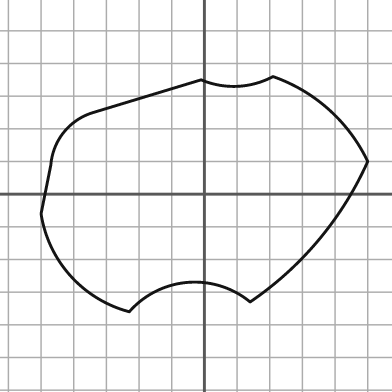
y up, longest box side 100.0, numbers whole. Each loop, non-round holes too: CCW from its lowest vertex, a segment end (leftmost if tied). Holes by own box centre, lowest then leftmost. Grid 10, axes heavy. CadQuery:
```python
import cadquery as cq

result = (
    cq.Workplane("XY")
    .moveTo(-23.0, -36.0)
    .threePointArc((-5.0, -27.0), (14.0, -33.0))
    .threePointArc((35.0, -14.0), (50.0, 10.0))
    .threePointArc((38.0, 26.0), (21.0, 36.0))
    .threePointArc((10.0, 33.0), (-1.0, 35.0))
    .lineTo(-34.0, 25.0)
    .threePointArc((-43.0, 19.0), (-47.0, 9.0))
    .lineTo(-50.0, -6.0)
    .threePointArc((-41.0, -25.0), (-23.0, -36.0))
    .close()
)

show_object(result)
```